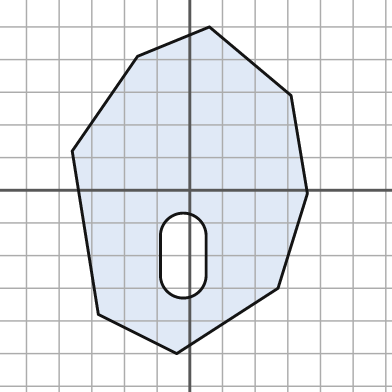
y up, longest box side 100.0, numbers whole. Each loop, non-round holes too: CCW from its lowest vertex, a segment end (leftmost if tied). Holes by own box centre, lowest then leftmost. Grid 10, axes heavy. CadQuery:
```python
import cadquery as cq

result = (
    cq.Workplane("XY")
    .moveTo(-4.0, -50.0)
    .lineTo(27.0, -30.0)
    .lineTo(36.0, -1.0)
    .lineTo(31.0, 29.0)
    .lineTo(6.0, 50.0)
    .lineTo(-16.0, 41.0)
    .lineTo(-36.0, 12.0)
    .lineTo(-28.0, -38.0)
    .close()
    .moveTo(-9.0, -26.0)
    .threePointArc((-2.0, -33.0), (5.0, -26.0))
    .lineTo(5.0, -14.0)
    .threePointArc((-2.0, -7.0), (-9.0, -14.0))
    .close()
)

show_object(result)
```